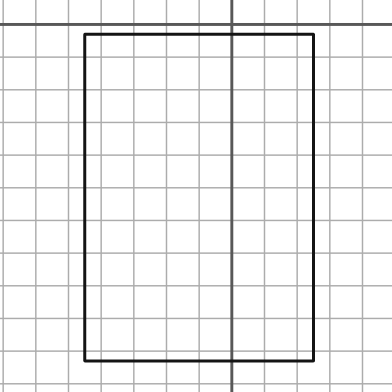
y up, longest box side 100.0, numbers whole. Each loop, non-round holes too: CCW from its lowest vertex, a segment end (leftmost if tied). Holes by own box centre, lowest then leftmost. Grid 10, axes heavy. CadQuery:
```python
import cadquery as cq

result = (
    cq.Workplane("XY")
    .moveTo(-45.0, -103.0)
    .lineTo(25.0, -103.0)
    .lineTo(25.0, -3.0)
    .lineTo(-45.0, -3.0)
    .close()
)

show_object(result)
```